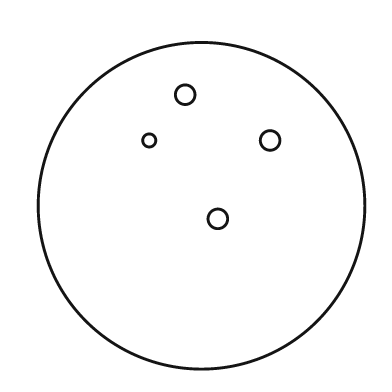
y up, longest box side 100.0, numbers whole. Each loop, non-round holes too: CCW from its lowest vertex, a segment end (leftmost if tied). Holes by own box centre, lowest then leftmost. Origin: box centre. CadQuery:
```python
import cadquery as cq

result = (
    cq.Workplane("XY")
    .moveTo(0.0, 0.0)
    .circle(50.0)
    .moveTo(5.0, -4.0)
    .circle(3.0)
    .moveTo(-16.0, 20.0)
    .circle(2.0)
    .moveTo(21.0, 20.0)
    .circle(3.0)
    .moveTo(-5.0, 34.0)
    .circle(3.0)
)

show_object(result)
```